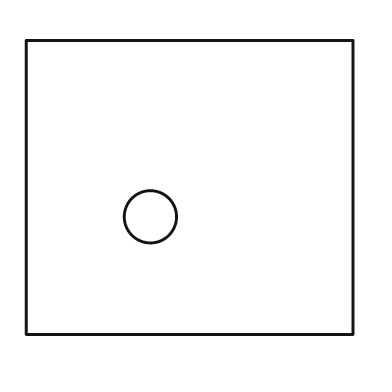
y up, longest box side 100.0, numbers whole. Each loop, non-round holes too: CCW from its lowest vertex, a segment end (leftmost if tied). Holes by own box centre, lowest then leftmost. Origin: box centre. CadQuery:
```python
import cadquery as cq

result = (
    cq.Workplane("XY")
    .moveTo(-50.0, -45.0)
    .lineTo(50.0, -45.0)
    .lineTo(50.0, 45.0)
    .lineTo(-50.0, 45.0)
    .close()
    .moveTo(-12.0, -9.0)
    .circle(8.0)
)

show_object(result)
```